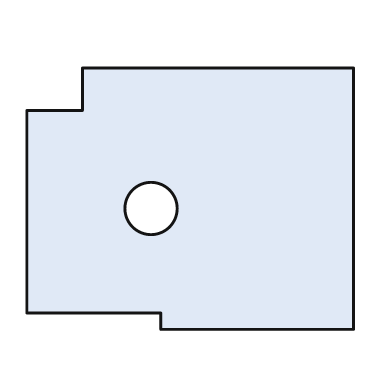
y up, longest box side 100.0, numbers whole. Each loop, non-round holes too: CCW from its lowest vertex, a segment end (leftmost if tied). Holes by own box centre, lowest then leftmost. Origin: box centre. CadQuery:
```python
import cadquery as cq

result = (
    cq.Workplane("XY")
    .moveTo(-9.0, -40.0)
    .lineTo(50.0, -40.0)
    .lineTo(50.0, 40.0)
    .lineTo(-33.0, 40.0)
    .lineTo(-33.0, 27.0)
    .lineTo(-50.0, 27.0)
    .lineTo(-50.0, -35.0)
    .lineTo(-9.0, -35.0)
    .close()
    .moveTo(-12.0, -3.0)
    .circle(8.0)
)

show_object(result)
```